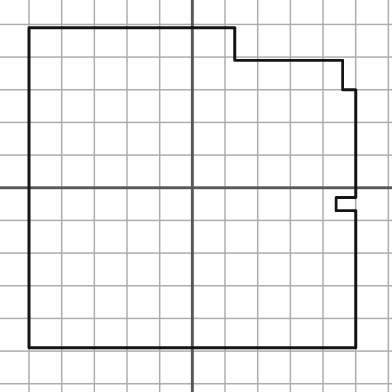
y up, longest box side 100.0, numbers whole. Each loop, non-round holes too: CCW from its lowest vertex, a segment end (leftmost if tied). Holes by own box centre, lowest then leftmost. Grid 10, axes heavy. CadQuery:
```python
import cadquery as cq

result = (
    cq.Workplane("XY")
    .moveTo(-50.0, -49.0)
    .lineTo(50.0, -49.0)
    .lineTo(50.0, -7.0)
    .lineTo(44.0, -7.0)
    .lineTo(44.0, -3.0)
    .lineTo(50.0, -3.0)
    .lineTo(50.0, 30.0)
    .lineTo(46.0, 30.0)
    .lineTo(46.0, 39.0)
    .lineTo(13.0, 39.0)
    .lineTo(13.0, 49.0)
    .lineTo(-50.0, 49.0)
    .close()
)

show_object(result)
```